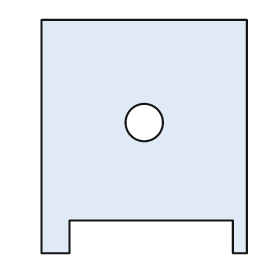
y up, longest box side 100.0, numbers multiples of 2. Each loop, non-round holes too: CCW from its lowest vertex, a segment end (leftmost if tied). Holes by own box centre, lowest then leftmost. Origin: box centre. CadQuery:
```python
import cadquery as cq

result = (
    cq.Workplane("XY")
    .moveTo(-44.0, -50.0)
    .lineTo(-32.0, -50.0)
    .lineTo(-32.0, -36.0)
    .lineTo(38.0, -36.0)
    .lineTo(38.0, -50.0)
    .lineTo(44.0, -50.0)
    .lineTo(44.0, 50.0)
    .lineTo(-44.0, 50.0)
    .close()
    .moveTo(0.0, 6.0)
    .circle(8.0)
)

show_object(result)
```